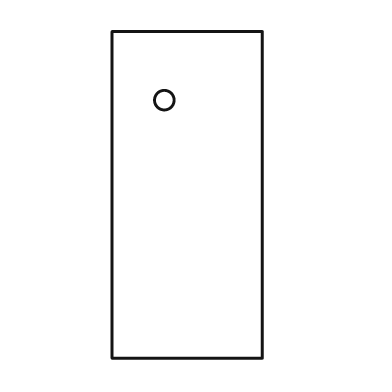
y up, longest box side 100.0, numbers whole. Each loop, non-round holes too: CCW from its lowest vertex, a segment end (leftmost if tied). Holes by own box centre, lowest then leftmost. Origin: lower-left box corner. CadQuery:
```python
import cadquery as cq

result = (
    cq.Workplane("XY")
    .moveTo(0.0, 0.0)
    .lineTo(46.0, 0.0)
    .lineTo(46.0, 100.0)
    .lineTo(0.0, 100.0)
    .close()
    .moveTo(16.0, 79.0)
    .circle(3.0)
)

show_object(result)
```